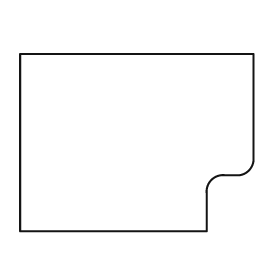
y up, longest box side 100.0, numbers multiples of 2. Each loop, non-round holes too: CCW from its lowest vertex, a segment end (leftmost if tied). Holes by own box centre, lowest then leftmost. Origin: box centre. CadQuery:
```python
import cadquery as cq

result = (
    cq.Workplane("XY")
    .moveTo(-50.0, -38.0)
    .lineTo(30.0, -38.0)
    .lineTo(30.0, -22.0)
    .threePointArc((32.0, -16.0), (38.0, -14.0))
    .lineTo(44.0, -14.0)
    .threePointArc((48.0, -12.0), (50.0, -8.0))
    .lineTo(50.0, 38.0)
    .lineTo(-50.0, 38.0)
    .close()
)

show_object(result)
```